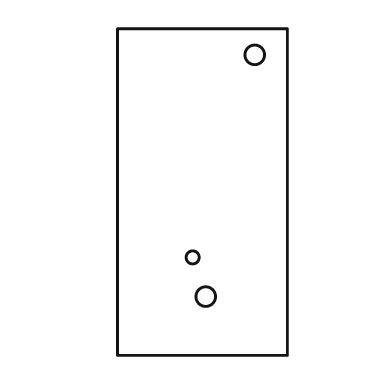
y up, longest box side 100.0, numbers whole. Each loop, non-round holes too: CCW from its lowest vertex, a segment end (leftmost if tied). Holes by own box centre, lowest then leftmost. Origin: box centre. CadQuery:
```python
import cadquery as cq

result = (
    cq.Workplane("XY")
    .moveTo(-26.0, -50.0)
    .lineTo(26.0, -50.0)
    .lineTo(26.0, 50.0)
    .lineTo(-26.0, 50.0)
    .close()
    .moveTo(1.0, -32.0)
    .circle(3.0)
    .moveTo(-3.0, -20.0)
    .circle(2.0)
    .moveTo(16.0, 42.0)
    .circle(3.0)
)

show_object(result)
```